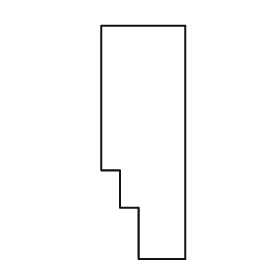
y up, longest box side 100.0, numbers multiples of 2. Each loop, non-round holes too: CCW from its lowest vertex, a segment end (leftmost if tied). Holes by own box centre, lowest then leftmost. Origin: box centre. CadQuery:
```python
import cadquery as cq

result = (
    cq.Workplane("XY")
    .moveTo(-2.0, -50.0)
    .lineTo(18.0, -50.0)
    .lineTo(18.0, 50.0)
    .lineTo(-18.0, 50.0)
    .lineTo(-18.0, -12.0)
    .lineTo(-10.0, -12.0)
    .lineTo(-10.0, -28.0)
    .lineTo(-2.0, -28.0)
    .close()
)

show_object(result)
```